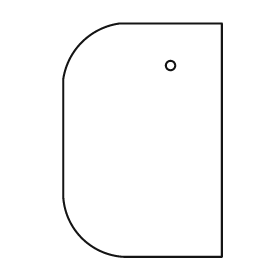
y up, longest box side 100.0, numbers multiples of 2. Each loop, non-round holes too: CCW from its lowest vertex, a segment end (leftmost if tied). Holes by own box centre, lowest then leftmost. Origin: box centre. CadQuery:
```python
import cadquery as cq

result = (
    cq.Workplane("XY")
    .moveTo(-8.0, -50.0)
    .lineTo(34.0, -50.0)
    .lineTo(34.0, 50.0)
    .lineTo(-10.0, 50.0)
    .threePointArc((-26.0, 42.0), (-34.0, 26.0))
    .lineTo(-34.0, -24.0)
    .threePointArc((-26.0, -42.0), (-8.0, -50.0))
    .close()
    .moveTo(12.0, 32.0)
    .circle(2.0)
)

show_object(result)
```